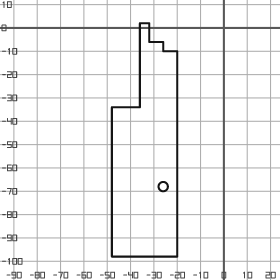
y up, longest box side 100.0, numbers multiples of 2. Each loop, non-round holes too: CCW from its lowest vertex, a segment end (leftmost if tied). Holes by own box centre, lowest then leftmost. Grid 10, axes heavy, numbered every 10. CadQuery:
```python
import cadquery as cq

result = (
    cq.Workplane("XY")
    .moveTo(-48.0, -98.0)
    .lineTo(-20.0, -98.0)
    .lineTo(-20.0, -10.0)
    .lineTo(-26.0, -10.0)
    .lineTo(-26.0, -6.0)
    .lineTo(-32.0, -6.0)
    .lineTo(-32.0, 2.0)
    .lineTo(-36.0, 2.0)
    .lineTo(-36.0, -34.0)
    .lineTo(-48.0, -34.0)
    .close()
    .moveTo(-26.0, -68.0)
    .circle(2.0)
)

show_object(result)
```